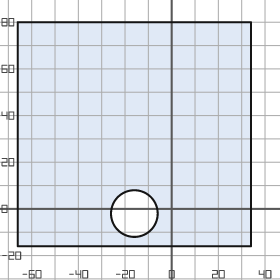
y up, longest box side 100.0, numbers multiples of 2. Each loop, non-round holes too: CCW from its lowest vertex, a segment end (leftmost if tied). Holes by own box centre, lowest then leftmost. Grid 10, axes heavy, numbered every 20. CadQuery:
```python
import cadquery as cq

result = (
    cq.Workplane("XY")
    .moveTo(-66.0, -16.0)
    .lineTo(34.0, -16.0)
    .lineTo(34.0, 80.0)
    .lineTo(-66.0, 80.0)
    .close()
    .moveTo(-16.0, -2.0)
    .circle(10.0)
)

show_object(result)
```